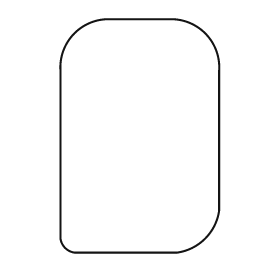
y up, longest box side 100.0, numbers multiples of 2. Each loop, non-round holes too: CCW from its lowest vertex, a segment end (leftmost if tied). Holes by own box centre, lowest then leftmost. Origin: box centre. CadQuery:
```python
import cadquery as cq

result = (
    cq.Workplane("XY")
    .moveTo(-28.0, -50.0)
    .lineTo(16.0, -50.0)
    .threePointArc((28.0, -44.0), (34.0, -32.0))
    .lineTo(34.0, 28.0)
    .threePointArc((28.0, 44.0), (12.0, 50.0))
    .lineTo(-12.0, 50.0)
    .threePointArc((-28.0, 44.0), (-34.0, 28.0))
    .lineTo(-34.0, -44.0)
    .threePointArc((-32.0, -48.0), (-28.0, -50.0))
    .close()
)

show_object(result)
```